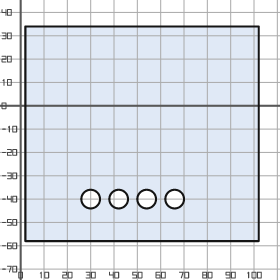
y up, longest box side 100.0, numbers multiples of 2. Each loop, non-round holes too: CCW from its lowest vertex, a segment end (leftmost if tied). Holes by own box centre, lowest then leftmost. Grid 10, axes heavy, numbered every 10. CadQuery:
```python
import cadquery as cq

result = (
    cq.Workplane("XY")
    .moveTo(2.0, -58.0)
    .lineTo(102.0, -58.0)
    .lineTo(102.0, 34.0)
    .lineTo(2.0, 34.0)
    .close()
    .moveTo(30.0, -40.0)
    .circle(4.0)
    .moveTo(42.0, -40.0)
    .circle(4.0)
    .moveTo(54.0, -40.0)
    .circle(4.0)
    .moveTo(66.0, -40.0)
    .circle(4.0)
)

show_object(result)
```